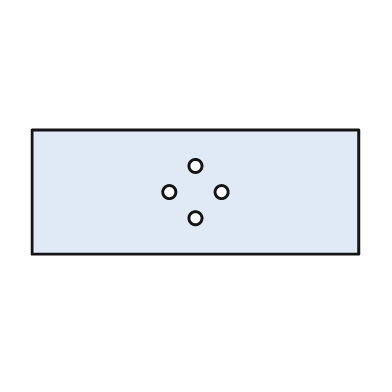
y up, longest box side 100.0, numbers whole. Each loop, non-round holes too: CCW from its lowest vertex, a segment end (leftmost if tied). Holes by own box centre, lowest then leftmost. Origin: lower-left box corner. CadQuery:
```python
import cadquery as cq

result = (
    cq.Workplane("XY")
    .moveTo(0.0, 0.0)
    .lineTo(100.0, 0.0)
    .lineTo(100.0, 38.0)
    .lineTo(0.0, 38.0)
    .close()
    .moveTo(50.0, 11.0)
    .circle(2.0)
    .moveTo(42.0, 19.0)
    .circle(2.0)
    .moveTo(58.0, 19.0)
    .circle(2.0)
    .moveTo(50.0, 27.0)
    .circle(2.0)
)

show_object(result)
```